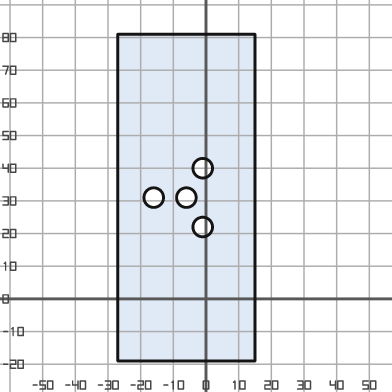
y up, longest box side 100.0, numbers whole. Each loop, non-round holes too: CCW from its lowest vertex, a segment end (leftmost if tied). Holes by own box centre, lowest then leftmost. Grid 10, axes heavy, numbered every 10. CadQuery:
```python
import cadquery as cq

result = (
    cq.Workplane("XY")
    .moveTo(-27.0, -19.0)
    .lineTo(15.0, -19.0)
    .lineTo(15.0, 81.0)
    .lineTo(-27.0, 81.0)
    .close()
    .moveTo(-1.0, 22.0)
    .circle(3.0)
    .moveTo(-16.0, 31.0)
    .circle(3.0)
    .moveTo(-6.0, 31.0)
    .circle(3.0)
    .moveTo(-1.0, 40.0)
    .circle(3.0)
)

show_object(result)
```